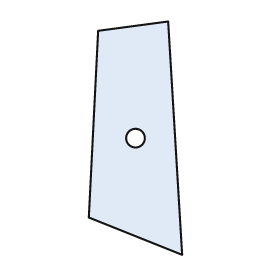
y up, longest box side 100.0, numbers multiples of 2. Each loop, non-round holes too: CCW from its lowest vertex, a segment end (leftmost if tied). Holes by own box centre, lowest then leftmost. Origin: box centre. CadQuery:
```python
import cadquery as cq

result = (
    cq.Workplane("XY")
    .moveTo(20.0, -50.0)
    .lineTo(14.0, 50.0)
    .lineTo(-16.0, 46.0)
    .lineTo(-20.0, -34.0)
    .close()
    .moveTo(0.0, 0.0)
    .circle(4.0)
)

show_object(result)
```